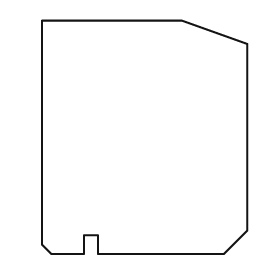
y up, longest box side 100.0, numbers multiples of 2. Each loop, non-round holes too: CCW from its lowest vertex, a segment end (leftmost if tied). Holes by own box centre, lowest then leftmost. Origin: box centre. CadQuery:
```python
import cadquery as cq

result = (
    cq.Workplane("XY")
    .moveTo(-40.0, -50.0)
    .lineTo(-26.0, -50.0)
    .lineTo(-26.0, -42.0)
    .lineTo(-20.0, -42.0)
    .lineTo(-20.0, -50.0)
    .lineTo(34.0, -50.0)
    .lineTo(44.0, -40.0)
    .lineTo(44.0, 40.0)
    .lineTo(16.0, 50.0)
    .lineTo(-44.0, 50.0)
    .lineTo(-44.0, -46.0)
    .close()
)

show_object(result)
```